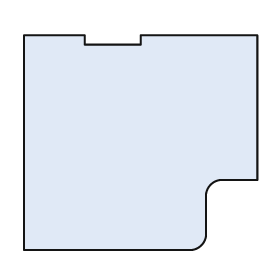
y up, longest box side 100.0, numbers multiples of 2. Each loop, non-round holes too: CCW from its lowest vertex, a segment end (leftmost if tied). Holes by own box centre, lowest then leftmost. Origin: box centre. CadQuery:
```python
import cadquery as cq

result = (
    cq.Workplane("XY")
    .moveTo(-50.0, -46.0)
    .lineTo(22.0, -46.0)
    .threePointArc((26.0, -44.0), (28.0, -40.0))
    .lineTo(28.0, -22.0)
    .threePointArc((30.0, -18.0), (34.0, -16.0))
    .lineTo(50.0, -16.0)
    .lineTo(50.0, 46.0)
    .lineTo(0.0, 46.0)
    .lineTo(0.0, 42.0)
    .lineTo(-24.0, 42.0)
    .lineTo(-24.0, 46.0)
    .lineTo(-50.0, 46.0)
    .close()
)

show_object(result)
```